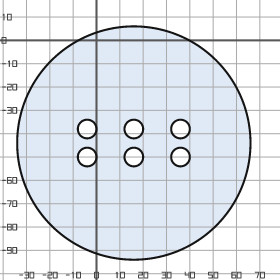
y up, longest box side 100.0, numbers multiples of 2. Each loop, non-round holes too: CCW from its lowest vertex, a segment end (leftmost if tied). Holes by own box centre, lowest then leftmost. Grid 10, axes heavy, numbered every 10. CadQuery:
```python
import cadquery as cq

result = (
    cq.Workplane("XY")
    .moveTo(16.0, -44.0)
    .circle(50.0)
    .moveTo(-4.0, -50.0)
    .circle(4.0)
    .moveTo(16.0, -50.0)
    .circle(4.0)
    .moveTo(36.0, -50.0)
    .circle(4.0)
    .moveTo(-4.0, -38.0)
    .circle(4.0)
    .moveTo(16.0, -38.0)
    .circle(4.0)
    .moveTo(36.0, -38.0)
    .circle(4.0)
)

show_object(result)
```